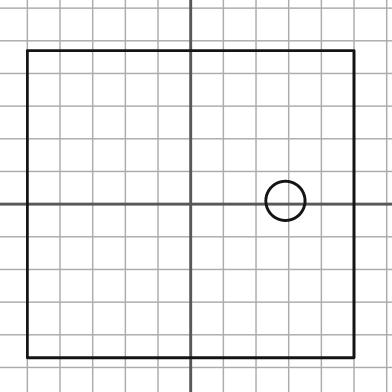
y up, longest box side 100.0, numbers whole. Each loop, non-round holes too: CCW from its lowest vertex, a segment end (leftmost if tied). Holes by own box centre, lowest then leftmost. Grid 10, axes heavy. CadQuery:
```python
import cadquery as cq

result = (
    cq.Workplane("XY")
    .moveTo(-50.0, -47.0)
    .lineTo(50.0, -47.0)
    .lineTo(50.0, 47.0)
    .lineTo(-50.0, 47.0)
    .close()
    .moveTo(29.0, 1.0)
    .circle(6.0)
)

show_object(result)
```